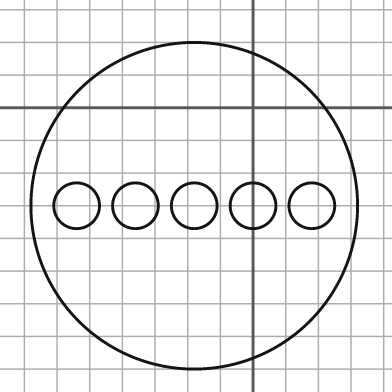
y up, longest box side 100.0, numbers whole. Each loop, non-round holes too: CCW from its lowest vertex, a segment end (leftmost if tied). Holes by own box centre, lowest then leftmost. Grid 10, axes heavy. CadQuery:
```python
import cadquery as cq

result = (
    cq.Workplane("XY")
    .moveTo(-18.0, -30.0)
    .circle(50.0)
    .moveTo(-54.0, -30.0)
    .circle(7.0)
    .moveTo(-36.0, -30.0)
    .circle(7.0)
    .moveTo(-18.0, -30.0)
    .circle(7.0)
    .moveTo(0.0, -30.0)
    .circle(7.0)
    .moveTo(18.0, -30.0)
    .circle(7.0)
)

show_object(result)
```